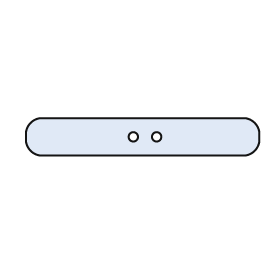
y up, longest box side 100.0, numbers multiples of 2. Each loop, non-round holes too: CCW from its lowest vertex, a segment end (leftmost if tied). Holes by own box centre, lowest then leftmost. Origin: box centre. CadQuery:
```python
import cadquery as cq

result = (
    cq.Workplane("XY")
    .moveTo(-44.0, -8.0)
    .lineTo(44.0, -8.0)
    .threePointArc((48.0, -6.0), (50.0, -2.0))
    .lineTo(50.0, 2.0)
    .threePointArc((48.0, 6.0), (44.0, 8.0))
    .lineTo(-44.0, 8.0)
    .threePointArc((-48.0, 6.0), (-50.0, 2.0))
    .lineTo(-50.0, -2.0)
    .threePointArc((-48.0, -6.0), (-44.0, -8.0))
    .close()
    .moveTo(-4.0, 0.0)
    .circle(2.0)
    .moveTo(6.0, 0.0)
    .circle(2.0)
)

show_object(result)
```